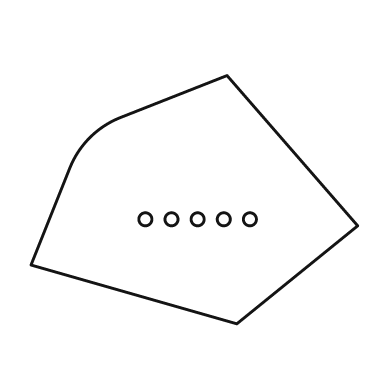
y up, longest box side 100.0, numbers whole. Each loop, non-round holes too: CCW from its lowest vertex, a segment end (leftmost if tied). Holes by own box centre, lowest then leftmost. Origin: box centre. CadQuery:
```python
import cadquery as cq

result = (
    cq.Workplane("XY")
    .moveTo(13.0, -38.0)
    .lineTo(50.0, -8.0)
    .lineTo(10.0, 38.0)
    .lineTo(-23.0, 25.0)
    .threePointArc((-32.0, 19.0), (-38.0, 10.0))
    .lineTo(-50.0, -20.0)
    .close()
    .moveTo(-15.0, -6.0)
    .circle(2.0)
    .moveTo(-7.0, -6.0)
    .circle(2.0)
    .moveTo(1.0, -6.0)
    .circle(2.0)
    .moveTo(9.0, -6.0)
    .circle(2.0)
    .moveTo(17.0, -6.0)
    .circle(2.0)
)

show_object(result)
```